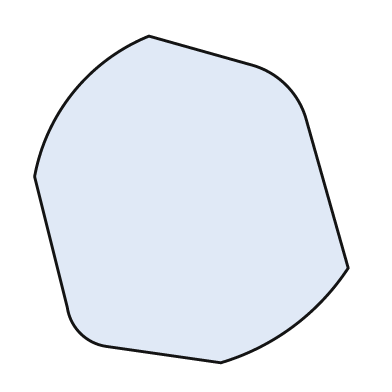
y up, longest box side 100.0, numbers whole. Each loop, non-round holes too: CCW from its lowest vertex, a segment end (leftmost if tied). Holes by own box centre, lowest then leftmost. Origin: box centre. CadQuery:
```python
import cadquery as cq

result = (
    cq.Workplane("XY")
    .moveTo(9.0, -50.0)
    .threePointArc((31.0, -39.0), (48.0, -21.0))
    .lineTo(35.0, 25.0)
    .threePointArc((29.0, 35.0), (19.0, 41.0))
    .lineTo(-13.0, 50.0)
    .threePointArc((-36.0, 33.0), (-48.0, 7.0))
    .lineTo(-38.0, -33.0)
    .threePointArc((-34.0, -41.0), (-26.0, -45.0))
    .close()
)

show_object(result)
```